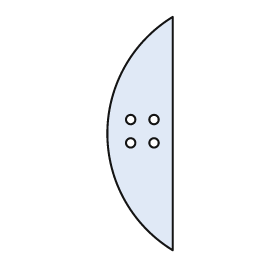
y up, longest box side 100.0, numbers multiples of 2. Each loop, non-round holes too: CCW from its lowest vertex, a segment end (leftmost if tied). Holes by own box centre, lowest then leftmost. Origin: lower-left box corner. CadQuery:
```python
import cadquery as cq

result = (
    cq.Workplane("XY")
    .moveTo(28.0, 0.0)
    .lineTo(28.0, 100.0)
    .threePointArc((0.0, 50.0), (28.0, 0.0))
    .close()
    .moveTo(10.0, 46.0)
    .circle(2.0)
    .moveTo(20.0, 46.0)
    .circle(2.0)
    .moveTo(10.0, 56.0)
    .circle(2.0)
    .moveTo(20.0, 56.0)
    .circle(2.0)
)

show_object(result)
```